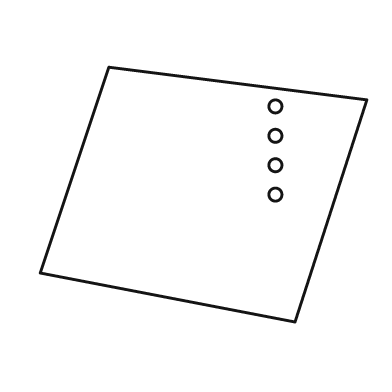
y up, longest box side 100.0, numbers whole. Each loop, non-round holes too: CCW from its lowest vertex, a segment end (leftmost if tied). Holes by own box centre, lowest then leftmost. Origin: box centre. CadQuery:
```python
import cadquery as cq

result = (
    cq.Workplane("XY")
    .moveTo(28.0, -39.0)
    .lineTo(50.0, 29.0)
    .lineTo(-29.0, 39.0)
    .lineTo(-50.0, -24.0)
    .close()
    .moveTo(22.0, 0.0)
    .circle(2.0)
    .moveTo(22.0, 9.0)
    .circle(2.0)
    .moveTo(22.0, 18.0)
    .circle(2.0)
    .moveTo(22.0, 27.0)
    .circle(2.0)
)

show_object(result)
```